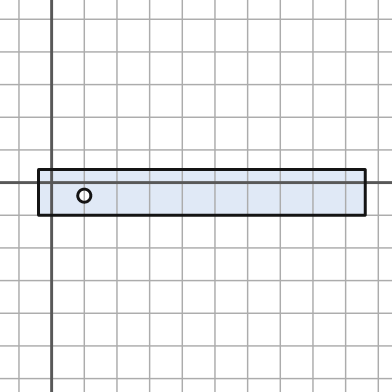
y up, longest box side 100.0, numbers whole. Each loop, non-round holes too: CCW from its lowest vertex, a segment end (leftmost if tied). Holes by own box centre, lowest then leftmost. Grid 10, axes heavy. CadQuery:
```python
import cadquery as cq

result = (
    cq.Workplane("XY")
    .moveTo(-4.0, -10.0)
    .lineTo(96.0, -10.0)
    .lineTo(96.0, 4.0)
    .lineTo(-4.0, 4.0)
    .close()
    .moveTo(10.0, -4.0)
    .circle(2.0)
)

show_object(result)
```